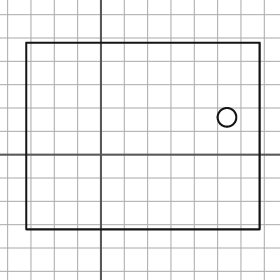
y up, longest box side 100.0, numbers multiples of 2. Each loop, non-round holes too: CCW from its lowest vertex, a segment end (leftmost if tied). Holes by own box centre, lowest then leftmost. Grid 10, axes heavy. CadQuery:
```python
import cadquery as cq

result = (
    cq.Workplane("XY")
    .moveTo(-32.0, -32.0)
    .lineTo(68.0, -32.0)
    .lineTo(68.0, 48.0)
    .lineTo(-32.0, 48.0)
    .close()
    .moveTo(54.0, 16.0)
    .circle(4.0)
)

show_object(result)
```